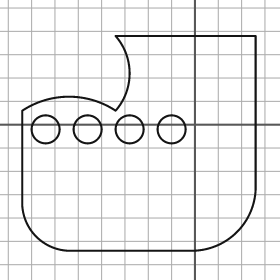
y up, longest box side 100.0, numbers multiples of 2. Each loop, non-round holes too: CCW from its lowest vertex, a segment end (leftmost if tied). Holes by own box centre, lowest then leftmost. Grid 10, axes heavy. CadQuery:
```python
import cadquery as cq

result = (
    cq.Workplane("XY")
    .moveTo(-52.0, -54.0)
    .lineTo(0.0, -54.0)
    .threePointArc((18.0, -46.0), (26.0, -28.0))
    .lineTo(26.0, 38.0)
    .lineTo(-34.0, 38.0)
    .threePointArc((-28.0, 22.0), (-34.0, 6.0))
    .threePointArc((-54.0, 12.0), (-74.0, 6.0))
    .lineTo(-74.0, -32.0)
    .threePointArc((-68.0, -48.0), (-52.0, -54.0))
    .close()
    .moveTo(-64.0, -2.0)
    .circle(6.0)
    .moveTo(-46.0, -2.0)
    .circle(6.0)
    .moveTo(-28.0, -2.0)
    .circle(6.0)
    .moveTo(-10.0, -2.0)
    .circle(6.0)
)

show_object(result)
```